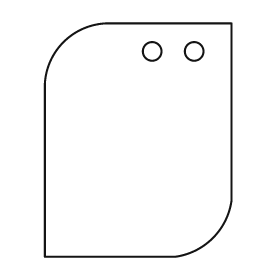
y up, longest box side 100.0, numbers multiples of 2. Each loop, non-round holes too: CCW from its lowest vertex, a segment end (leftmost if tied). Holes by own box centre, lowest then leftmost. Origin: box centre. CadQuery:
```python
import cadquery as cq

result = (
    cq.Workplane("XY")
    .moveTo(-40.0, -50.0)
    .lineTo(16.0, -50.0)
    .threePointArc((32.0, -42.0), (40.0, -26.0))
    .lineTo(40.0, 50.0)
    .lineTo(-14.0, 50.0)
    .threePointArc((-32.0, 42.0), (-40.0, 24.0))
    .close()
    .moveTo(6.0, 38.0)
    .circle(4.0)
    .moveTo(24.0, 38.0)
    .circle(4.0)
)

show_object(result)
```